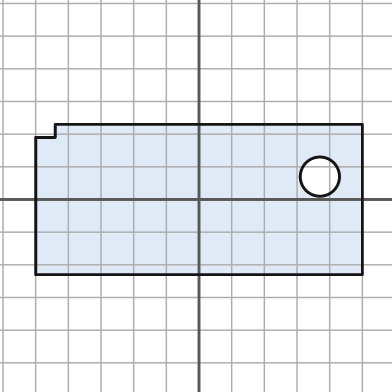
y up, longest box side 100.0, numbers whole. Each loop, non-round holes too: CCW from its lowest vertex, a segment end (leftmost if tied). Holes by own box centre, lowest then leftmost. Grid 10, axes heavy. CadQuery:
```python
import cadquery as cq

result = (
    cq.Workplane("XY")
    .moveTo(-50.0, -23.0)
    .lineTo(50.0, -23.0)
    .lineTo(50.0, 23.0)
    .lineTo(-44.0, 23.0)
    .lineTo(-44.0, 19.0)
    .lineTo(-50.0, 19.0)
    .close()
    .moveTo(37.0, 7.0)
    .circle(6.0)
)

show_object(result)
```